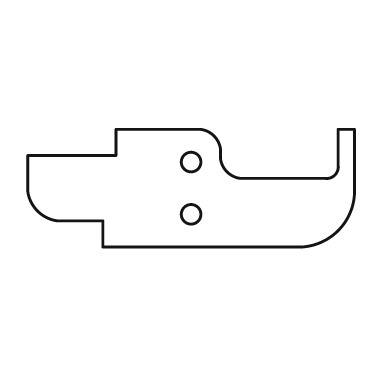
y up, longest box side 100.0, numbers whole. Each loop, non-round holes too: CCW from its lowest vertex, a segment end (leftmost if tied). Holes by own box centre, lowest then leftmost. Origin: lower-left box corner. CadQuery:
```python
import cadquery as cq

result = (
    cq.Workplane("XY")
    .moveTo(23.0, 0.0)
    .lineTo(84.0, 0.0)
    .threePointArc((95.0, 5.0), (100.0, 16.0))
    .lineTo(100.0, 36.0)
    .lineTo(95.0, 36.0)
    .lineTo(95.0, 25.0)
    .threePointArc((94.0, 22.0), (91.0, 21.0))
    .lineTo(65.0, 21.0)
    .threePointArc((61.0, 23.0), (59.0, 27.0))
    .lineTo(59.0, 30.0)
    .threePointArc((57.0, 34.0), (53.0, 36.0))
    .lineTo(27.0, 36.0)
    .lineTo(27.0, 28.0)
    .lineTo(0.0, 28.0)
    .lineTo(0.0, 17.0)
    .threePointArc((3.0, 11.0), (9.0, 8.0))
    .lineTo(23.0, 8.0)
    .close()
    .moveTo(50.0, 10.0)
    .circle(3.0)
    .moveTo(50.0, 26.0)
    .circle(3.0)
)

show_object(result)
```